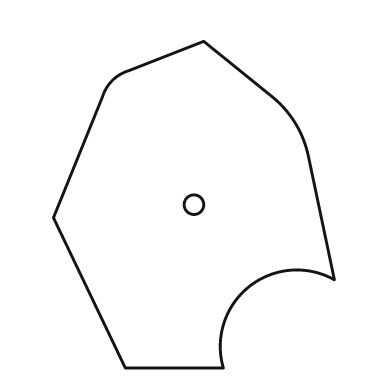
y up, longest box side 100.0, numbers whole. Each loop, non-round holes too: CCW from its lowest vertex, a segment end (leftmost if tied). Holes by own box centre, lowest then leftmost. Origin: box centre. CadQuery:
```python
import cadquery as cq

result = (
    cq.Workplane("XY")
    .moveTo(-21.0, -50.0)
    .lineTo(9.0, -50.0)
    .threePointArc((17.0, -25.0), (43.0, -23.0))
    .lineTo(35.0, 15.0)
    .threePointArc((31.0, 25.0), (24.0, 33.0))
    .lineTo(3.0, 50.0)
    .lineTo(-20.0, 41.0)
    .threePointArc((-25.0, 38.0), (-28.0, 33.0))
    .lineTo(-43.0, -4.0)
    .close()
    .moveTo(0.0, 0.0)
    .circle(3.0)
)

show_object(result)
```